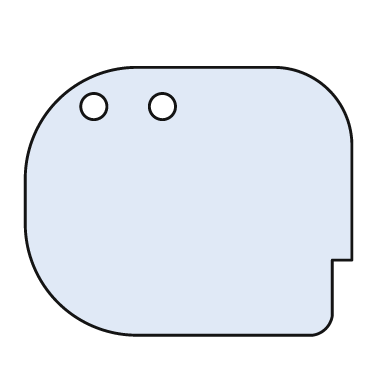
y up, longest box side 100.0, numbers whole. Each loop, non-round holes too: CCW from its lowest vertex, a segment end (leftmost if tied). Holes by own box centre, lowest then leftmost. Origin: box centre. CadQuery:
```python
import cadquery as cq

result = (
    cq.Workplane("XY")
    .moveTo(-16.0, -41.0)
    .lineTo(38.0, -41.0)
    .threePointArc((42.0, -39.0), (44.0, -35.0))
    .lineTo(44.0, -18.0)
    .lineTo(50.0, -18.0)
    .lineTo(50.0, 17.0)
    .threePointArc((43.0, 34.0), (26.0, 41.0))
    .lineTo(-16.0, 41.0)
    .threePointArc((-40.0, 31.0), (-50.0, 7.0))
    .lineTo(-50.0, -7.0)
    .threePointArc((-40.0, -31.0), (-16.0, -41.0))
    .close()
    .moveTo(-29.0, 29.0)
    .circle(4.0)
    .moveTo(-8.0, 29.0)
    .circle(4.0)
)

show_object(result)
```